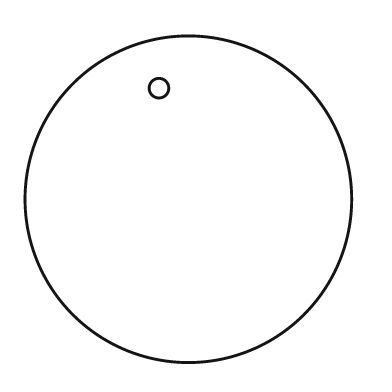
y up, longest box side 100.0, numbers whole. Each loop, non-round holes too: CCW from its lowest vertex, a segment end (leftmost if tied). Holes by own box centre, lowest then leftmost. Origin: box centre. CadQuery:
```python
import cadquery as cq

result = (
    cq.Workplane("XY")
    .moveTo(0.0, 0.0)
    .circle(50.0)
    .moveTo(-9.0, 34.0)
    .circle(3.0)
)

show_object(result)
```